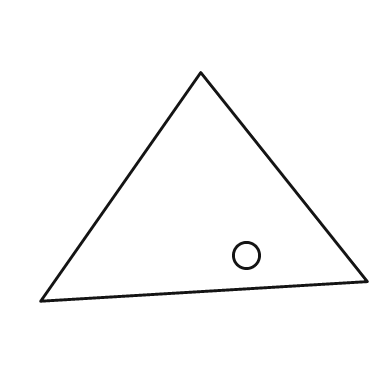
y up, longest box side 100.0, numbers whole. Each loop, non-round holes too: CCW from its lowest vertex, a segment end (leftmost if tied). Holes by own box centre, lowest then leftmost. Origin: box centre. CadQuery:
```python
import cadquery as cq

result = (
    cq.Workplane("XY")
    .moveTo(-50.0, -35.0)
    .lineTo(50.0, -29.0)
    .lineTo(-1.0, 35.0)
    .close()
    .moveTo(13.0, -21.0)
    .circle(4.0)
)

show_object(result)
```